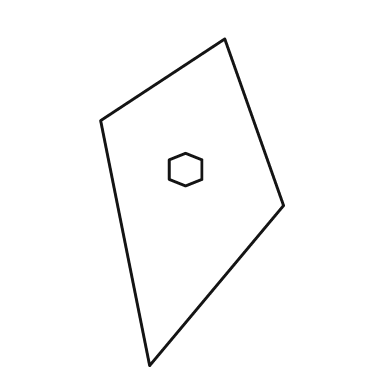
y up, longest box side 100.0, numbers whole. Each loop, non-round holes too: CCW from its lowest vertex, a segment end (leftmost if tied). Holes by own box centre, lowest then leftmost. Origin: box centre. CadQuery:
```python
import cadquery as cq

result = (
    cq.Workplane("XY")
    .moveTo(-13.0, -50.0)
    .lineTo(28.0, -1.0)
    .lineTo(10.0, 50.0)
    .lineTo(-28.0, 25.0)
    .close()
    .moveTo(-2.0, 5.0)
    .lineTo(3.0, 7.0)
    .lineTo(3.0, 13.0)
    .lineTo(-2.0, 15.0)
    .lineTo(-7.0, 13.0)
    .lineTo(-7.0, 7.0)
    .close()
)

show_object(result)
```